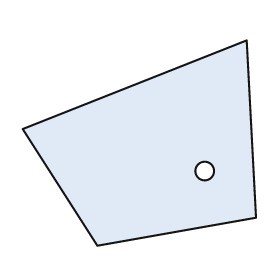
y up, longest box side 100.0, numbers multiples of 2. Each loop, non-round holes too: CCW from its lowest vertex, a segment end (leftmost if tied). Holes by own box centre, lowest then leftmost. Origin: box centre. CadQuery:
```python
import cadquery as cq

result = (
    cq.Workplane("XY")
    .moveTo(-18.0, -44.0)
    .lineTo(50.0, -32.0)
    .lineTo(46.0, 44.0)
    .lineTo(-50.0, 6.0)
    .close()
    .moveTo(28.0, -12.0)
    .circle(4.0)
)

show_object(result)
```